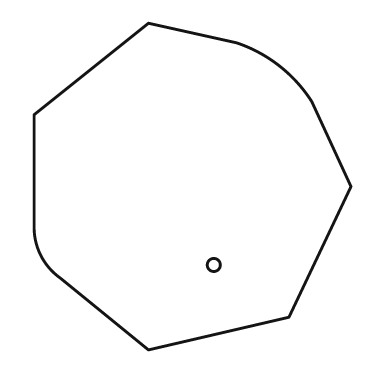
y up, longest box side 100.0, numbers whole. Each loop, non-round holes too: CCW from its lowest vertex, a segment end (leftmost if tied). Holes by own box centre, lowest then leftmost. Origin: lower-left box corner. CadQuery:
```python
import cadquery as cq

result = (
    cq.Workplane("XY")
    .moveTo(35.0, 0.0)
    .lineTo(78.0, 10.0)
    .lineTo(97.0, 50.0)
    .lineTo(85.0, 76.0)
    .threePointArc((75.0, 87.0), (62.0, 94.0))
    .lineTo(35.0, 100.0)
    .lineTo(0.0, 72.0)
    .lineTo(0.0, 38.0)
    .threePointArc((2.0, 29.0), (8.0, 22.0))
    .close()
    .moveTo(55.0, 26.0)
    .circle(2.0)
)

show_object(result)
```